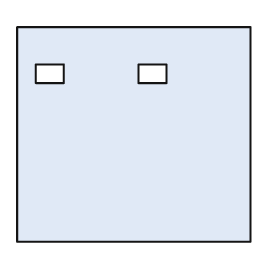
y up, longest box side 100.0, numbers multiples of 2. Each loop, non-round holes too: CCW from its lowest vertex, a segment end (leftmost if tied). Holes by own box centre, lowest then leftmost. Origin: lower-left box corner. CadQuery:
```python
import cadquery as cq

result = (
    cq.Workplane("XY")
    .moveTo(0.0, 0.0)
    .lineTo(100.0, 0.0)
    .lineTo(100.0, 92.0)
    .lineTo(0.0, 92.0)
    .close()
    .moveTo(8.0, 68.0)
    .lineTo(20.0, 68.0)
    .lineTo(20.0, 76.0)
    .lineTo(8.0, 76.0)
    .close()
    .moveTo(52.0, 68.0)
    .lineTo(64.0, 68.0)
    .lineTo(64.0, 76.0)
    .lineTo(52.0, 76.0)
    .close()
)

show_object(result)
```